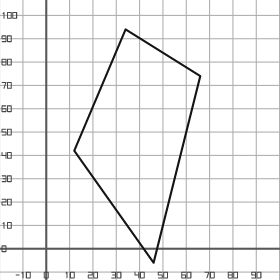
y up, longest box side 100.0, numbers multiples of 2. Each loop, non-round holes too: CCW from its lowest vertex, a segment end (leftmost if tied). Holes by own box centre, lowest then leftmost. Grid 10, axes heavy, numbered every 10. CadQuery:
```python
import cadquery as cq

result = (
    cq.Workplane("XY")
    .moveTo(46.0, -6.0)
    .lineTo(66.0, 74.0)
    .lineTo(34.0, 94.0)
    .lineTo(12.0, 42.0)
    .close()
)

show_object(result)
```